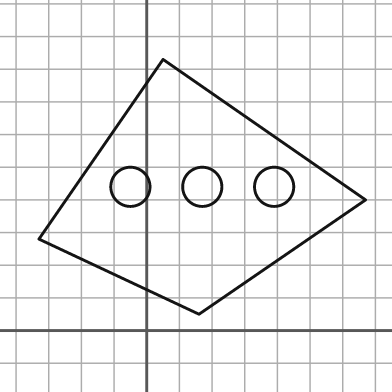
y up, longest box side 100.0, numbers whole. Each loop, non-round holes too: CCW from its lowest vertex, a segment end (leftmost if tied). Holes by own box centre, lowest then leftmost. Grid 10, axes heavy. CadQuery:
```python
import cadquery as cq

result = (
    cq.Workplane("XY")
    .moveTo(16.0, 5.0)
    .lineTo(67.0, 40.0)
    .lineTo(5.0, 83.0)
    .lineTo(-33.0, 28.0)
    .close()
    .moveTo(-5.0, 44.0)
    .circle(6.0)
    .moveTo(17.0, 44.0)
    .circle(6.0)
    .moveTo(39.0, 44.0)
    .circle(6.0)
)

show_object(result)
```